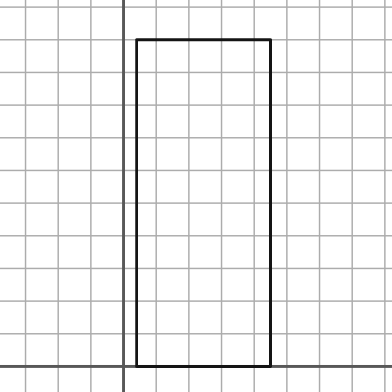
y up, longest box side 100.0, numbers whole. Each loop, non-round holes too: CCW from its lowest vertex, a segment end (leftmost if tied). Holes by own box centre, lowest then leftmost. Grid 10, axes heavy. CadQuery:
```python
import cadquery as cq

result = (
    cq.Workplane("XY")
    .moveTo(4.0, 0.0)
    .lineTo(45.0, 0.0)
    .lineTo(45.0, 100.0)
    .lineTo(4.0, 100.0)
    .close()
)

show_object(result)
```